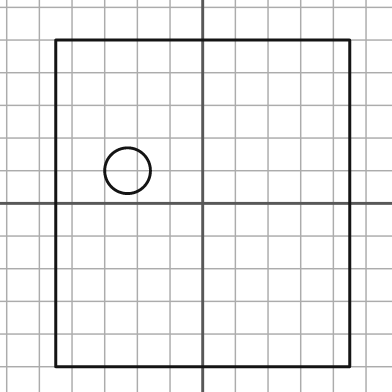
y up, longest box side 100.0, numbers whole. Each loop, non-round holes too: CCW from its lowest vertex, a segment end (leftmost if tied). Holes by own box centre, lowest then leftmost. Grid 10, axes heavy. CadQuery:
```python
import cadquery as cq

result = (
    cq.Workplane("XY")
    .moveTo(-45.0, -50.0)
    .lineTo(45.0, -50.0)
    .lineTo(45.0, 50.0)
    .lineTo(-45.0, 50.0)
    .close()
    .moveTo(-23.0, 10.0)
    .circle(7.0)
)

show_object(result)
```